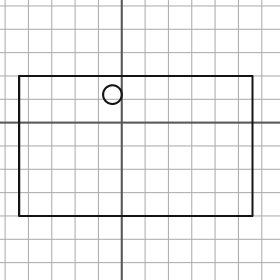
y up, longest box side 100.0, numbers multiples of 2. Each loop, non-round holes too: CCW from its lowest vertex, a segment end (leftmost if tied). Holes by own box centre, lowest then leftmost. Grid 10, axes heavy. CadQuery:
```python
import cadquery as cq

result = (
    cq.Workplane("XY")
    .moveTo(-44.0, -40.0)
    .lineTo(56.0, -40.0)
    .lineTo(56.0, 20.0)
    .lineTo(-44.0, 20.0)
    .close()
    .moveTo(-4.0, 12.0)
    .circle(4.0)
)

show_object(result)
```